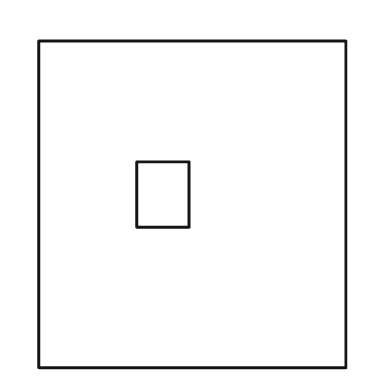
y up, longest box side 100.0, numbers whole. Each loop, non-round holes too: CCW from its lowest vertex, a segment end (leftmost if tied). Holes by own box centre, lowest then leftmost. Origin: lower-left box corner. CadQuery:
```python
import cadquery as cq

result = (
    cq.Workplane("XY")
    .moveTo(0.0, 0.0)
    .lineTo(94.0, 0.0)
    .lineTo(94.0, 100.0)
    .lineTo(0.0, 100.0)
    .close()
    .moveTo(30.0, 43.0)
    .lineTo(46.0, 43.0)
    .lineTo(46.0, 63.0)
    .lineTo(30.0, 63.0)
    .close()
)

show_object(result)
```